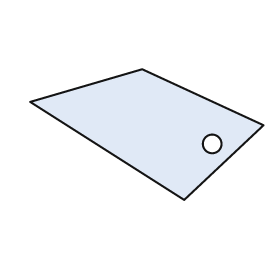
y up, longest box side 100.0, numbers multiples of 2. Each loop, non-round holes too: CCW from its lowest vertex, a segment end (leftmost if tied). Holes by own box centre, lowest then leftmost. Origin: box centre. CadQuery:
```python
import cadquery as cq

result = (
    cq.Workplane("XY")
    .moveTo(16.0, -28.0)
    .lineTo(50.0, 4.0)
    .lineTo(-2.0, 28.0)
    .lineTo(-50.0, 14.0)
    .close()
    .moveTo(28.0, -4.0)
    .circle(4.0)
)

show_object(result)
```